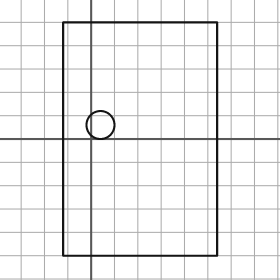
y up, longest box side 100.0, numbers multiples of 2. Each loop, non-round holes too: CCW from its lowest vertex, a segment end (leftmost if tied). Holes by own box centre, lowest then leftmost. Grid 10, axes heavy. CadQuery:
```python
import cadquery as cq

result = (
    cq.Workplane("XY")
    .moveTo(-12.0, -50.0)
    .lineTo(54.0, -50.0)
    .lineTo(54.0, 50.0)
    .lineTo(-12.0, 50.0)
    .close()
    .moveTo(4.0, 6.0)
    .circle(6.0)
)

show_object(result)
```